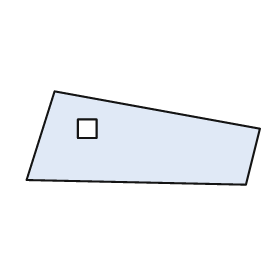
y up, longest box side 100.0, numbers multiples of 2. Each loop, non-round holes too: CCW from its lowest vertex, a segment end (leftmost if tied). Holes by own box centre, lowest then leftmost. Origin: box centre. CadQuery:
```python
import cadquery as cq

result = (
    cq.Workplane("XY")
    .moveTo(44.0, -20.0)
    .lineTo(50.0, 4.0)
    .lineTo(-38.0, 20.0)
    .lineTo(-50.0, -18.0)
    .close()
    .moveTo(-28.0, 0.0)
    .lineTo(-20.0, 0.0)
    .lineTo(-20.0, 8.0)
    .lineTo(-28.0, 8.0)
    .close()
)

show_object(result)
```